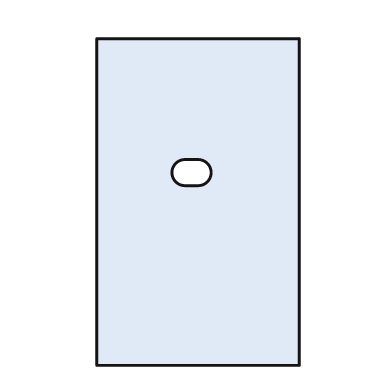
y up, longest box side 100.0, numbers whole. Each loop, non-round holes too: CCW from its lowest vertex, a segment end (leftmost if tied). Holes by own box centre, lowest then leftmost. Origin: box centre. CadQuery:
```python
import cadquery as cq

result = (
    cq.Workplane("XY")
    .moveTo(-31.0, -50.0)
    .lineTo(31.0, -50.0)
    .lineTo(31.0, 50.0)
    .lineTo(-31.0, 50.0)
    .close()
    .moveTo(-4.0, 5.0)
    .lineTo(0.0, 5.0)
    .threePointArc((4.0, 9.0), (0.0, 13.0))
    .lineTo(-4.0, 13.0)
    .threePointArc((-8.0, 9.0), (-4.0, 5.0))
    .close()
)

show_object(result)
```